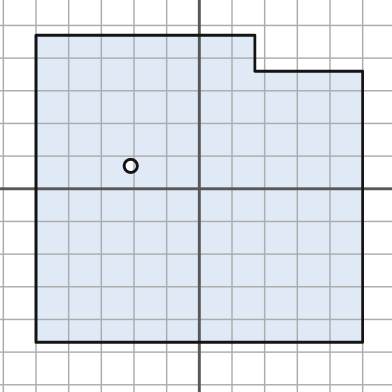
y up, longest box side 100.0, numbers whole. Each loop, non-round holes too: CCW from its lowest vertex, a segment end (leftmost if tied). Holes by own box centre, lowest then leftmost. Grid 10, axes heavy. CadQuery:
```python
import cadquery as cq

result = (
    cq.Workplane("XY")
    .moveTo(-50.0, -47.0)
    .lineTo(50.0, -47.0)
    .lineTo(50.0, 36.0)
    .lineTo(17.0, 36.0)
    .lineTo(17.0, 47.0)
    .lineTo(-50.0, 47.0)
    .close()
    .moveTo(-21.0, 7.0)
    .circle(2.0)
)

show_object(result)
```